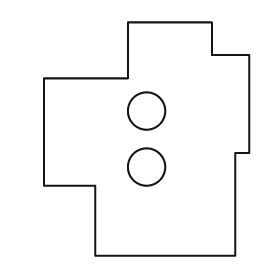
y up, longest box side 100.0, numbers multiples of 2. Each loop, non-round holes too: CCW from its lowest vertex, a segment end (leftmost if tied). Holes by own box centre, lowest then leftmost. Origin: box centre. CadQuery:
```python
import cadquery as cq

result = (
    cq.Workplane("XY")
    .moveTo(-22.0, -50.0)
    .lineTo(38.0, -50.0)
    .lineTo(38.0, -6.0)
    .lineTo(44.0, -6.0)
    .lineTo(44.0, 36.0)
    .lineTo(28.0, 36.0)
    .lineTo(28.0, 50.0)
    .lineTo(-8.0, 50.0)
    .lineTo(-8.0, 26.0)
    .lineTo(-44.0, 26.0)
    .lineTo(-44.0, -20.0)
    .lineTo(-22.0, -20.0)
    .close()
    .moveTo(0.0, -12.0)
    .circle(8.0)
    .moveTo(0.0, 12.0)
    .circle(8.0)
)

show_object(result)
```